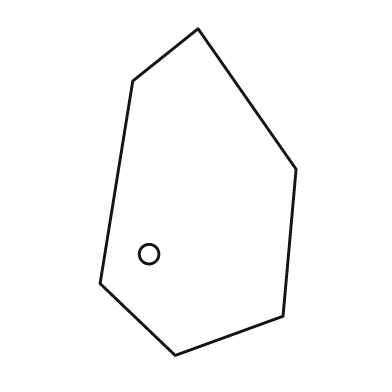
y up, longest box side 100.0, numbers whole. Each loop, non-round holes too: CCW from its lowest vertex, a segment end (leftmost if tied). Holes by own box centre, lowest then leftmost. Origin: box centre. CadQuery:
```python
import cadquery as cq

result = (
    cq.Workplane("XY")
    .moveTo(-7.0, -50.0)
    .lineTo(26.0, -38.0)
    .lineTo(30.0, 7.0)
    .lineTo(0.0, 50.0)
    .lineTo(-20.0, 34.0)
    .lineTo(-30.0, -28.0)
    .close()
    .moveTo(-15.0, -19.0)
    .circle(3.0)
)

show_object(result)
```